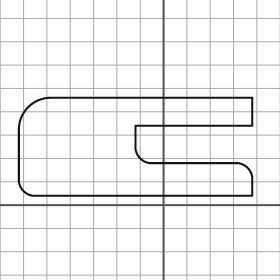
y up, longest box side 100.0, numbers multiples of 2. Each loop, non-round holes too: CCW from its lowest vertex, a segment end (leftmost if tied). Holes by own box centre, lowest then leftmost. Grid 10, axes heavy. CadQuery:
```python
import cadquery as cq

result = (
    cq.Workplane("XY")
    .moveTo(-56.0, 4.0)
    .lineTo(38.0, 4.0)
    .lineTo(38.0, 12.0)
    .threePointArc((36.0, 16.0), (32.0, 18.0))
    .lineTo(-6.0, 18.0)
    .threePointArc((-10.0, 20.0), (-12.0, 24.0))
    .lineTo(-12.0, 34.0)
    .lineTo(38.0, 34.0)
    .lineTo(38.0, 46.0)
    .lineTo(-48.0, 46.0)
    .threePointArc((-58.0, 42.0), (-62.0, 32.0))
    .lineTo(-62.0, 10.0)
    .threePointArc((-60.0, 6.0), (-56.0, 4.0))
    .close()
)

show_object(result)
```